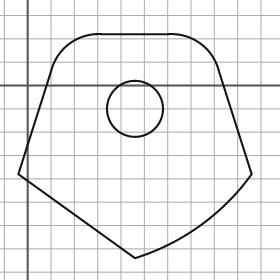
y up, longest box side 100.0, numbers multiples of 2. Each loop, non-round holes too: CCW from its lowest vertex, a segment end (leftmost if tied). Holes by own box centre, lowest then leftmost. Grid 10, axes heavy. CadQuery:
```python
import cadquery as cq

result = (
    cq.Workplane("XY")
    .moveTo(46.0, -74.0)
    .threePointArc((74.0, -60.0), (96.0, -38.0))
    .lineTo(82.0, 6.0)
    .threePointArc((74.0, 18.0), (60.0, 22.0))
    .lineTo(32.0, 22.0)
    .threePointArc((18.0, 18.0), (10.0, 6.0))
    .lineTo(-4.0, -38.0)
    .close()
    .moveTo(46.0, -10.0)
    .circle(12.0)
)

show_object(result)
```